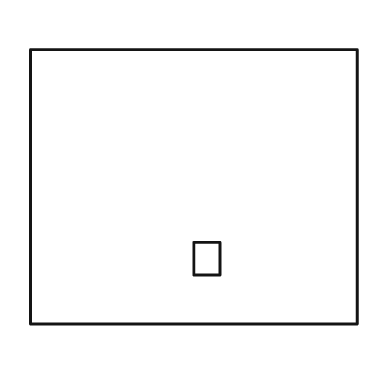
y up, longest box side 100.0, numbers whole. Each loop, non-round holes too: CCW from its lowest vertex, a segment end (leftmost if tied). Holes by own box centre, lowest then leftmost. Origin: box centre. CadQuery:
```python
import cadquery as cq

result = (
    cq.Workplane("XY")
    .moveTo(-50.0, -42.0)
    .lineTo(50.0, -42.0)
    .lineTo(50.0, 42.0)
    .lineTo(-50.0, 42.0)
    .close()
    .moveTo(0.0, -27.0)
    .lineTo(8.0, -27.0)
    .lineTo(8.0, -17.0)
    .lineTo(0.0, -17.0)
    .close()
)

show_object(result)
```